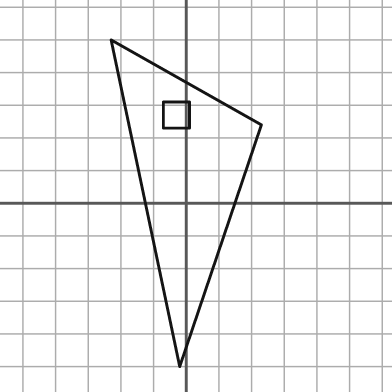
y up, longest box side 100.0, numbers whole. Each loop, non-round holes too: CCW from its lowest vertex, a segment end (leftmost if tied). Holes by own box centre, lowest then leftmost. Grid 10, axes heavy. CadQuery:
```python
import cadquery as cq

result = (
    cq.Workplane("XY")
    .moveTo(-2.0, -50.0)
    .lineTo(23.0, 24.0)
    .lineTo(-23.0, 50.0)
    .close()
    .moveTo(-7.0, 23.0)
    .lineTo(1.0, 23.0)
    .lineTo(1.0, 31.0)
    .lineTo(-7.0, 31.0)
    .close()
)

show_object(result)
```